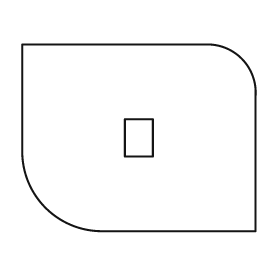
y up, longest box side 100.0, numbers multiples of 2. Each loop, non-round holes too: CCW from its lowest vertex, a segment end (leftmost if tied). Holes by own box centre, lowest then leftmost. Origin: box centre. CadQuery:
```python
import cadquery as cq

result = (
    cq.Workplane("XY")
    .moveTo(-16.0, -40.0)
    .lineTo(50.0, -40.0)
    .lineTo(50.0, 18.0)
    .threePointArc((44.0, 34.0), (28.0, 40.0))
    .lineTo(-50.0, 40.0)
    .lineTo(-50.0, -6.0)
    .threePointArc((-40.0, -30.0), (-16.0, -40.0))
    .close()
    .moveTo(-6.0, -8.0)
    .lineTo(6.0, -8.0)
    .lineTo(6.0, 8.0)
    .lineTo(-6.0, 8.0)
    .close()
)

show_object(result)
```